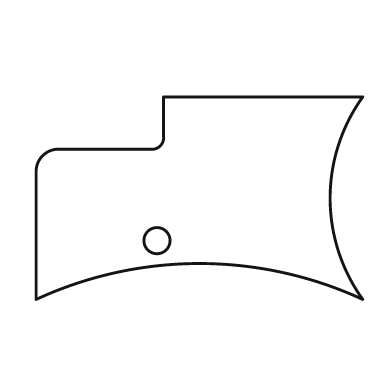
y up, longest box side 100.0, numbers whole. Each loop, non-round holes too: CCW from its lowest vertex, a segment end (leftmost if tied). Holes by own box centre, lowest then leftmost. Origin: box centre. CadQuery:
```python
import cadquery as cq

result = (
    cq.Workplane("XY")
    .moveTo(-50.0, -31.0)
    .threePointArc((0.0, -20.0), (50.0, -31.0))
    .threePointArc((40.0, 0.0), (50.0, 31.0))
    .lineTo(-11.0, 31.0)
    .lineTo(-11.0, 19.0)
    .threePointArc((-12.0, 16.0), (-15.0, 15.0))
    .lineTo(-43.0, 15.0)
    .threePointArc((-48.0, 13.0), (-50.0, 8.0))
    .close()
    .moveTo(-13.0, -13.0)
    .circle(4.0)
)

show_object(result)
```